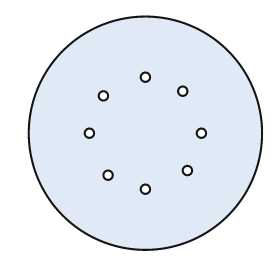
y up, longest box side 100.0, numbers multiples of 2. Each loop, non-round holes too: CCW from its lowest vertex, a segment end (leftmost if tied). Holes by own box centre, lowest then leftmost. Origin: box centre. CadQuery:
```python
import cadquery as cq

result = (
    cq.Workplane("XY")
    .moveTo(0.0, 0.0)
    .circle(50.0)
    .moveTo(0.0, -24.0)
    .circle(2.0)
    .moveTo(-16.0, -18.0)
    .circle(2.0)
    .moveTo(18.0, -16.0)
    .circle(2.0)
    .moveTo(-24.0, 0.0)
    .circle(2.0)
    .moveTo(24.0, 0.0)
    .circle(2.0)
    .moveTo(-18.0, 16.0)
    .circle(2.0)
    .moveTo(16.0, 18.0)
    .circle(2.0)
    .moveTo(0.0, 24.0)
    .circle(2.0)
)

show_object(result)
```